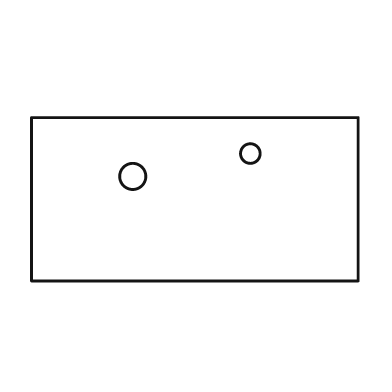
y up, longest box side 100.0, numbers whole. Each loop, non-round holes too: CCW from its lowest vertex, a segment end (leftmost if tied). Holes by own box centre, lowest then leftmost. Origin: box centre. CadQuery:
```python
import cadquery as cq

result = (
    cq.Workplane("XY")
    .moveTo(-50.0, -25.0)
    .lineTo(50.0, -25.0)
    .lineTo(50.0, 25.0)
    .lineTo(-50.0, 25.0)
    .close()
    .moveTo(-19.0, 7.0)
    .circle(4.0)
    .moveTo(17.0, 14.0)
    .circle(3.0)
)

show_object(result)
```